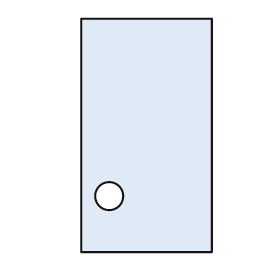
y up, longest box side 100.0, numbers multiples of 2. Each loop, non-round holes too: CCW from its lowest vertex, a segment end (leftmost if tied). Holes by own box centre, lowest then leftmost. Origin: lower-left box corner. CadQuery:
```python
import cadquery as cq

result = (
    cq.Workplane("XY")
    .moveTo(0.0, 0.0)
    .lineTo(56.0, 0.0)
    .lineTo(56.0, 100.0)
    .lineTo(0.0, 100.0)
    .close()
    .moveTo(12.0, 24.0)
    .circle(6.0)
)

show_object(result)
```